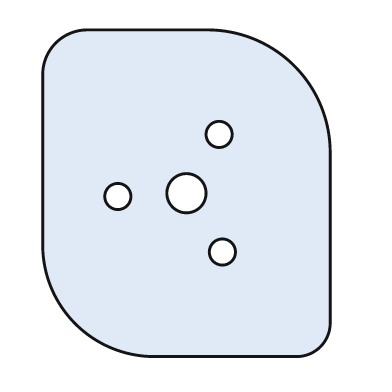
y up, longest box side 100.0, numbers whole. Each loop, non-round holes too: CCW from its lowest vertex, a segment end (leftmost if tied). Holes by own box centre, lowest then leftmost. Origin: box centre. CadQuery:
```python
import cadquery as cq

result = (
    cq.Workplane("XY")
    .moveTo(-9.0, -50.0)
    .lineTo(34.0, -50.0)
    .threePointArc((41.0, -47.0), (44.0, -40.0))
    .lineTo(44.0, 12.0)
    .threePointArc((33.0, 39.0), (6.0, 50.0))
    .lineTo(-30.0, 50.0)
    .threePointArc((-40.0, 46.0), (-44.0, 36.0))
    .lineTo(-44.0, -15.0)
    .threePointArc((-34.0, -40.0), (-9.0, -50.0))
    .close()
    .moveTo(11.0, -18.0)
    .circle(4.0)
    .moveTo(-21.0, -1.0)
    .circle(4.0)
    .moveTo(0.0, 0.0)
    .circle(6.0)
    .moveTo(10.0, 18.0)
    .circle(4.0)
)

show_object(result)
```